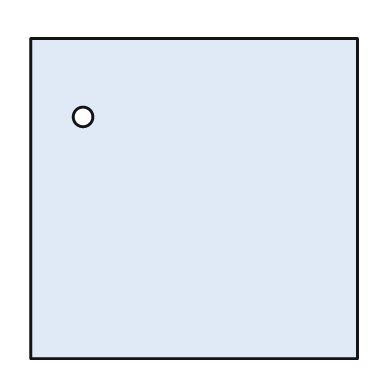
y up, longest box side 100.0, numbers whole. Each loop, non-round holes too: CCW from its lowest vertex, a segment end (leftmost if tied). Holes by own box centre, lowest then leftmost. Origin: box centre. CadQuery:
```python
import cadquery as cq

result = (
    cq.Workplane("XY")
    .moveTo(-50.0, -49.0)
    .lineTo(50.0, -49.0)
    .lineTo(50.0, 49.0)
    .lineTo(-50.0, 49.0)
    .close()
    .moveTo(-34.0, 25.0)
    .circle(3.0)
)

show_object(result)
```